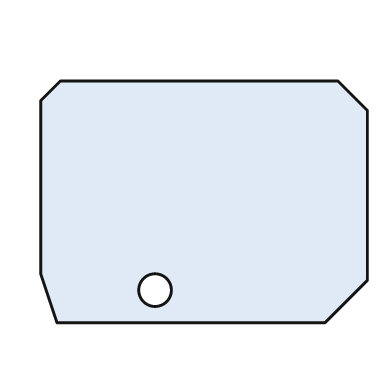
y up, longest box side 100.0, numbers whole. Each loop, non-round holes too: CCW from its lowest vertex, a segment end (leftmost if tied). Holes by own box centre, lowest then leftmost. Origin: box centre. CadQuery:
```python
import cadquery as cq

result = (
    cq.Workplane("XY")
    .moveTo(-45.0, -37.0)
    .lineTo(37.0, -37.0)
    .lineTo(50.0, -24.0)
    .lineTo(50.0, 28.0)
    .lineTo(41.0, 37.0)
    .lineTo(-44.0, 37.0)
    .lineTo(-50.0, 31.0)
    .lineTo(-50.0, -22.0)
    .close()
    .moveTo(-15.0, -27.0)
    .circle(5.0)
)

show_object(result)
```